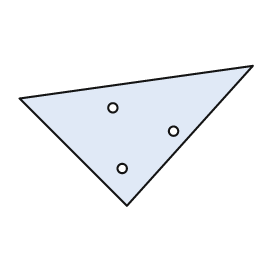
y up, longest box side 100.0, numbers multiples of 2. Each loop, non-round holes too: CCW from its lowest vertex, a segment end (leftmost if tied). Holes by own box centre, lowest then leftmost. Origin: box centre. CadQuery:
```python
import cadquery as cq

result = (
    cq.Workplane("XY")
    .moveTo(-4.0, -30.0)
    .lineTo(50.0, 30.0)
    .lineTo(-50.0, 16.0)
    .close()
    .moveTo(-6.0, -14.0)
    .circle(2.0)
    .moveTo(16.0, 2.0)
    .circle(2.0)
    .moveTo(-10.0, 12.0)
    .circle(2.0)
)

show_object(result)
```